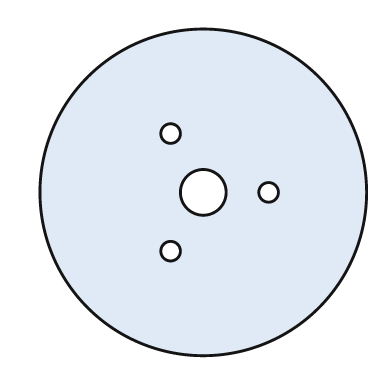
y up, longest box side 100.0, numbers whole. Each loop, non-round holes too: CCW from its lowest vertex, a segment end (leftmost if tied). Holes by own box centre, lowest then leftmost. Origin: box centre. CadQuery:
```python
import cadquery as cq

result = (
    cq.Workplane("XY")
    .moveTo(0.0, 0.0)
    .circle(50.0)
    .moveTo(-10.0, -18.0)
    .circle(3.0)
    .moveTo(0.0, 0.0)
    .circle(7.0)
    .moveTo(20.0, 0.0)
    .circle(3.0)
    .moveTo(-10.0, 18.0)
    .circle(3.0)
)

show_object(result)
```